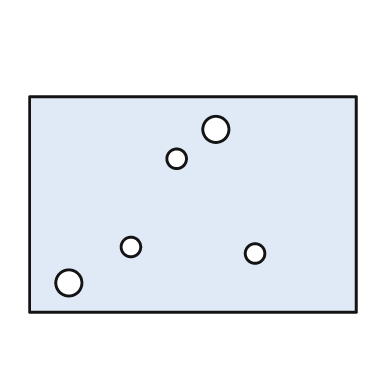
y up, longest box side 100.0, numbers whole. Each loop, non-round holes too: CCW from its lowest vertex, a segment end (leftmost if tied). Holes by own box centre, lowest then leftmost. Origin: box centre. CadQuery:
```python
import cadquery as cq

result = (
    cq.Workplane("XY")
    .moveTo(-50.0, -33.0)
    .lineTo(50.0, -33.0)
    .lineTo(50.0, 33.0)
    .lineTo(-50.0, 33.0)
    .close()
    .moveTo(-38.0, -24.0)
    .circle(4.0)
    .moveTo(19.0, -15.0)
    .circle(3.0)
    .moveTo(-19.0, -13.0)
    .circle(3.0)
    .moveTo(-5.0, 14.0)
    .circle(3.0)
    .moveTo(7.0, 23.0)
    .circle(4.0)
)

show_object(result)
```